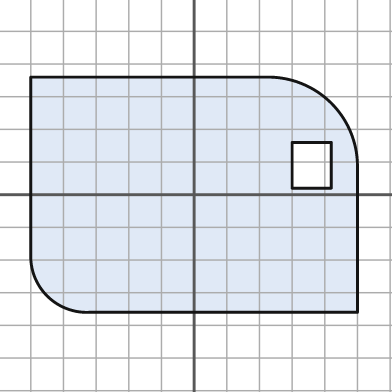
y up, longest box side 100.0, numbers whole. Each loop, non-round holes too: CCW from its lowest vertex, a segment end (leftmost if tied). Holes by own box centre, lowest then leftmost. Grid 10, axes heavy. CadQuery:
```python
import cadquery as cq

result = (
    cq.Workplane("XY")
    .moveTo(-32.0, -36.0)
    .lineTo(50.0, -36.0)
    .lineTo(50.0, 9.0)
    .threePointArc((42.0, 28.0), (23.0, 36.0))
    .lineTo(-50.0, 36.0)
    .lineTo(-50.0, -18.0)
    .threePointArc((-45.0, -31.0), (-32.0, -36.0))
    .close()
    .moveTo(30.0, 2.0)
    .lineTo(42.0, 2.0)
    .lineTo(42.0, 16.0)
    .lineTo(30.0, 16.0)
    .close()
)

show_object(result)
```